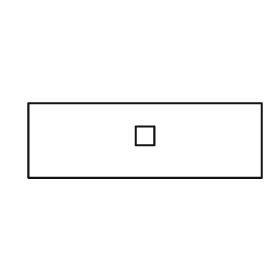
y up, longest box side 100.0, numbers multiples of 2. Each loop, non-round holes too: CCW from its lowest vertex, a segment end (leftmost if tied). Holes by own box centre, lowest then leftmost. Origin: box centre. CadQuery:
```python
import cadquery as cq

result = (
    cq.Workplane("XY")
    .moveTo(-50.0, -16.0)
    .lineTo(50.0, -16.0)
    .lineTo(50.0, 16.0)
    .lineTo(-50.0, 16.0)
    .close()
    .moveTo(-4.0, -2.0)
    .lineTo(4.0, -2.0)
    .lineTo(4.0, 6.0)
    .lineTo(-4.0, 6.0)
    .close()
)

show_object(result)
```